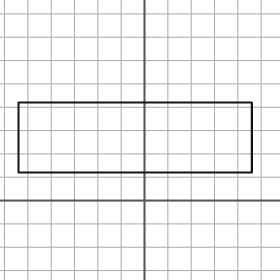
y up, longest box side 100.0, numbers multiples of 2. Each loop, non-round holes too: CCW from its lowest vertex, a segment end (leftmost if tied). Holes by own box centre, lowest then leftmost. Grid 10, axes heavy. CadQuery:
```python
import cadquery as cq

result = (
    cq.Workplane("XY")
    .moveTo(-54.0, 12.0)
    .lineTo(46.0, 12.0)
    .lineTo(46.0, 42.0)
    .lineTo(-54.0, 42.0)
    .close()
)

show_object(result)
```